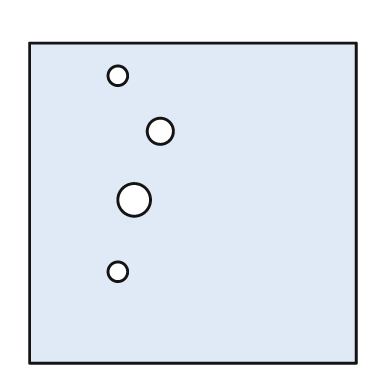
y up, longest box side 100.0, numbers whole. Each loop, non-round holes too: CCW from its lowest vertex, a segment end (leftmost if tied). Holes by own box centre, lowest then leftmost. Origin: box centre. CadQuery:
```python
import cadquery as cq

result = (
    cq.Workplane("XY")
    .moveTo(-50.0, -49.0)
    .lineTo(50.0, -49.0)
    .lineTo(50.0, 49.0)
    .lineTo(-50.0, 49.0)
    .close()
    .moveTo(-23.0, -21.0)
    .circle(3.0)
    .moveTo(-18.0, 1.0)
    .circle(5.0)
    .moveTo(-10.0, 22.0)
    .circle(4.0)
    .moveTo(-23.0, 39.0)
    .circle(3.0)
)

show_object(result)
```